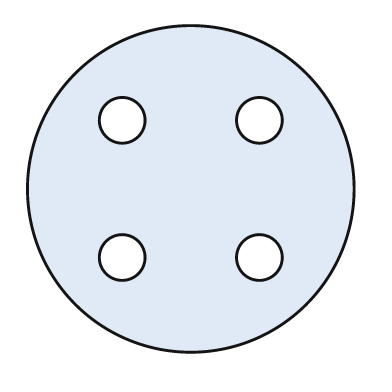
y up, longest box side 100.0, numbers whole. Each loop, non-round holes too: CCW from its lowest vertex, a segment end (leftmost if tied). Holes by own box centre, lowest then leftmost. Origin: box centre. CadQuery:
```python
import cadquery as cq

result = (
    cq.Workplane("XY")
    .moveTo(0.0, 0.0)
    .circle(50.0)
    .moveTo(-21.0, -21.0)
    .circle(7.0)
    .moveTo(21.0, -21.0)
    .circle(7.0)
    .moveTo(-21.0, 21.0)
    .circle(7.0)
    .moveTo(21.0, 21.0)
    .circle(7.0)
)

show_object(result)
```